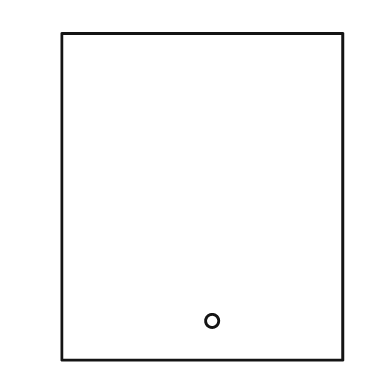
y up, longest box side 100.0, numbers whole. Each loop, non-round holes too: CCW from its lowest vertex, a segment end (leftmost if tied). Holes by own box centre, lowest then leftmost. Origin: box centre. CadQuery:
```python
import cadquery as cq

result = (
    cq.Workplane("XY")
    .moveTo(-43.0, -50.0)
    .lineTo(43.0, -50.0)
    .lineTo(43.0, 50.0)
    .lineTo(-43.0, 50.0)
    .close()
    .moveTo(3.0, -38.0)
    .circle(2.0)
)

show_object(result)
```